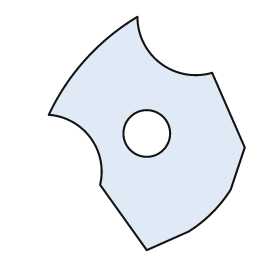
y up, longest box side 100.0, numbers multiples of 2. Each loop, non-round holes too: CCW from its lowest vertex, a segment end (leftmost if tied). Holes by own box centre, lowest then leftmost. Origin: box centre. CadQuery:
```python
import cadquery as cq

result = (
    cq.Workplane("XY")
    .moveTo(0.0, -50.0)
    .lineTo(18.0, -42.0)
    .threePointArc((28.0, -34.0), (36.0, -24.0))
    .lineTo(42.0, -6.0)
    .lineTo(28.0, 26.0)
    .threePointArc((6.0, 30.0), (-4.0, 50.0))
    .threePointArc((-26.0, 32.0), (-42.0, 8.0))
    .threePointArc((-24.0, -2.0), (-20.0, -22.0))
    .close()
    .moveTo(0.0, 0.0)
    .circle(10.0)
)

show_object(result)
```